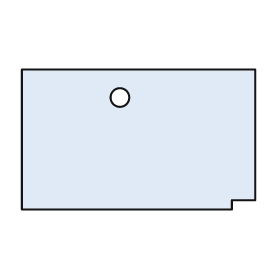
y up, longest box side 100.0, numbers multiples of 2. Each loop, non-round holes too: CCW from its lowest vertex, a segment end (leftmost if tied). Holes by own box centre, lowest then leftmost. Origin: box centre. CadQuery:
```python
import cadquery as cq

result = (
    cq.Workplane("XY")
    .moveTo(-50.0, -30.0)
    .lineTo(40.0, -30.0)
    .lineTo(40.0, -26.0)
    .lineTo(50.0, -26.0)
    .lineTo(50.0, 30.0)
    .lineTo(-50.0, 30.0)
    .close()
    .moveTo(-8.0, 18.0)
    .circle(4.0)
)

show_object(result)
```